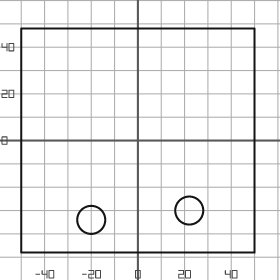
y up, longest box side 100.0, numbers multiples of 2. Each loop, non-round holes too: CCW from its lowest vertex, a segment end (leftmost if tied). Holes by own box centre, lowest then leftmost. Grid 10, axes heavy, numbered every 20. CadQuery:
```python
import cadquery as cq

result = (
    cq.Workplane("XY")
    .moveTo(-50.0, -48.0)
    .lineTo(50.0, -48.0)
    .lineTo(50.0, 48.0)
    .lineTo(-50.0, 48.0)
    .close()
    .moveTo(-20.0, -34.0)
    .circle(6.0)
    .moveTo(22.0, -30.0)
    .circle(6.0)
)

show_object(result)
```